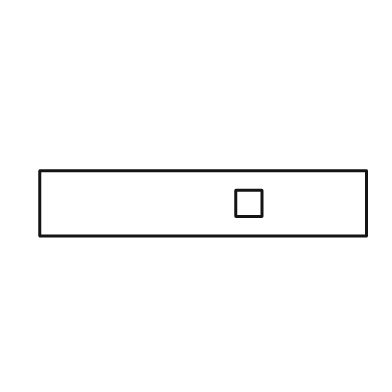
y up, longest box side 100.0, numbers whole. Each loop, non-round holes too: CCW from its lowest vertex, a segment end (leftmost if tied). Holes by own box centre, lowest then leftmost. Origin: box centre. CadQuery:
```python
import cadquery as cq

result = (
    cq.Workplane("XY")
    .moveTo(-50.0, -10.0)
    .lineTo(50.0, -10.0)
    .lineTo(50.0, 10.0)
    .lineTo(-50.0, 10.0)
    .close()
    .moveTo(10.0, -4.0)
    .lineTo(18.0, -4.0)
    .lineTo(18.0, 4.0)
    .lineTo(10.0, 4.0)
    .close()
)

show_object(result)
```